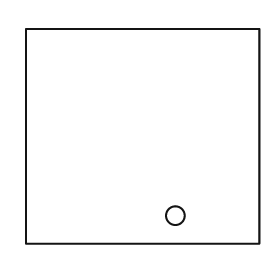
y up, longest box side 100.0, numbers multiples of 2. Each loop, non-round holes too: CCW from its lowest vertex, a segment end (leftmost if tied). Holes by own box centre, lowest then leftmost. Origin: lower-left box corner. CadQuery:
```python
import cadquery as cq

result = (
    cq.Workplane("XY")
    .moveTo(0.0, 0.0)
    .lineTo(100.0, 0.0)
    .lineTo(100.0, 92.0)
    .lineTo(0.0, 92.0)
    .close()
    .moveTo(64.0, 12.0)
    .circle(4.0)
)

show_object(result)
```